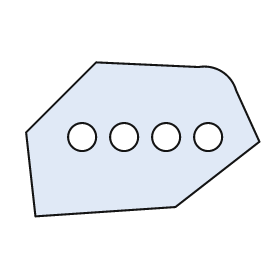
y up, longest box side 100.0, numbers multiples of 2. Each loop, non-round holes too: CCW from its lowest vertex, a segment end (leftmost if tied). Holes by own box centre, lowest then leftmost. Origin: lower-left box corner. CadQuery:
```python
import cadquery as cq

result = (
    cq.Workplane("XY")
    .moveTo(4.0, 0.0)
    .lineTo(64.0, 4.0)
    .lineTo(100.0, 32.0)
    .lineTo(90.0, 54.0)
    .threePointArc((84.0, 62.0), (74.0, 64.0))
    .lineTo(30.0, 66.0)
    .lineTo(0.0, 36.0)
    .close()
    .moveTo(24.0, 34.0)
    .circle(6.0)
    .moveTo(42.0, 34.0)
    .circle(6.0)
    .moveTo(60.0, 34.0)
    .circle(6.0)
    .moveTo(78.0, 34.0)
    .circle(6.0)
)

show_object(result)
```